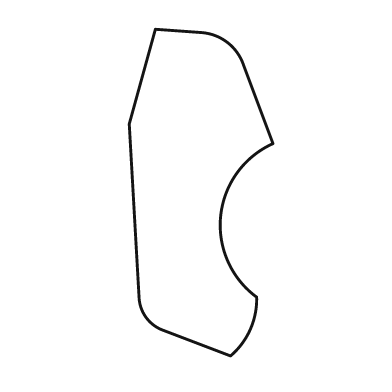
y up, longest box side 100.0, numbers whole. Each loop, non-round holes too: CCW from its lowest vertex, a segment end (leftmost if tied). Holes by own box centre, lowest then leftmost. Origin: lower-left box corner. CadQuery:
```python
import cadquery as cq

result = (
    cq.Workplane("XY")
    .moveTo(31.0, 0.0)
    .threePointArc((37.0, 8.0), (39.0, 18.0))
    .threePointArc((28.0, 43.0), (44.0, 65.0))
    .lineTo(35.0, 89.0)
    .threePointArc((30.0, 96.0), (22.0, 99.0))
    .lineTo(8.0, 100.0)
    .lineTo(0.0, 71.0)
    .lineTo(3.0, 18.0)
    .threePointArc((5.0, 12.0), (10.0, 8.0))
    .close()
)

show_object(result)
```